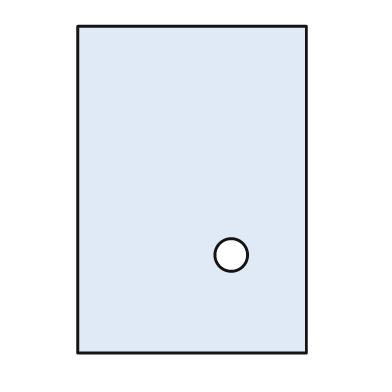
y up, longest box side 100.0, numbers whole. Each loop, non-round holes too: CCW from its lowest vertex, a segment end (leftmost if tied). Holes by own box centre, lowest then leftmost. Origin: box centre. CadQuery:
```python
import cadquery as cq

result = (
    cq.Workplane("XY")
    .moveTo(-35.0, -50.0)
    .lineTo(35.0, -50.0)
    .lineTo(35.0, 50.0)
    .lineTo(-35.0, 50.0)
    .close()
    .moveTo(12.0, -20.0)
    .circle(5.0)
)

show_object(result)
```